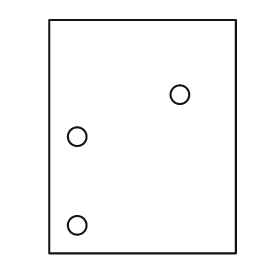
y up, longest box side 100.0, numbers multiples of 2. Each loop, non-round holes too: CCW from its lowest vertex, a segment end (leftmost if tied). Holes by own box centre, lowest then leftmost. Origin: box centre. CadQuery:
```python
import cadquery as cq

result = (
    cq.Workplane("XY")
    .moveTo(-40.0, -50.0)
    .lineTo(40.0, -50.0)
    .lineTo(40.0, 50.0)
    .lineTo(-40.0, 50.0)
    .close()
    .moveTo(-28.0, -38.0)
    .circle(4.0)
    .moveTo(-28.0, 0.0)
    .circle(4.0)
    .moveTo(16.0, 18.0)
    .circle(4.0)
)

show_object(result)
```